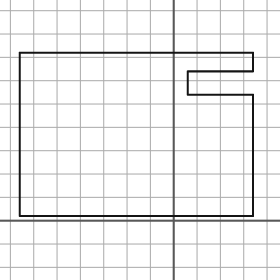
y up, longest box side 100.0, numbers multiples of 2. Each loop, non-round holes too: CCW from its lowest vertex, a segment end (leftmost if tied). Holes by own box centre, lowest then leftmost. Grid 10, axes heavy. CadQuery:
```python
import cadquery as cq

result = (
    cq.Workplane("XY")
    .moveTo(-66.0, 2.0)
    .lineTo(34.0, 2.0)
    .lineTo(34.0, 54.0)
    .lineTo(6.0, 54.0)
    .lineTo(6.0, 64.0)
    .lineTo(34.0, 64.0)
    .lineTo(34.0, 72.0)
    .lineTo(-66.0, 72.0)
    .close()
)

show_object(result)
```